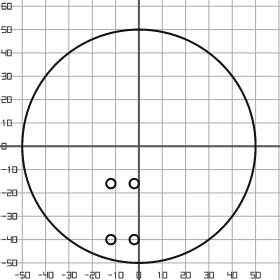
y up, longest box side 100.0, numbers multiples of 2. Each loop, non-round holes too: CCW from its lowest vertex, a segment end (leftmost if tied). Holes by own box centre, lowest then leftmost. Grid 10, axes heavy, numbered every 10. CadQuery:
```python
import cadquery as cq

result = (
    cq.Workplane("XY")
    .moveTo(0.0, 0.0)
    .circle(50.0)
    .moveTo(-12.0, -40.0)
    .circle(2.0)
    .moveTo(-2.0, -40.0)
    .circle(2.0)
    .moveTo(-12.0, -16.0)
    .circle(2.0)
    .moveTo(-2.0, -16.0)
    .circle(2.0)
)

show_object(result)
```